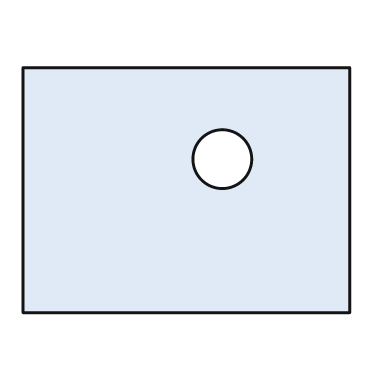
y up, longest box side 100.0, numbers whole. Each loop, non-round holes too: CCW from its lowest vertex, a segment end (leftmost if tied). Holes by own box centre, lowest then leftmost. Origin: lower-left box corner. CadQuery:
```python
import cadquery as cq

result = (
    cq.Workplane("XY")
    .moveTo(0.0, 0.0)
    .lineTo(100.0, 0.0)
    .lineTo(100.0, 75.0)
    .lineTo(0.0, 75.0)
    .close()
    .moveTo(61.0, 47.0)
    .circle(9.0)
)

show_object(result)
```